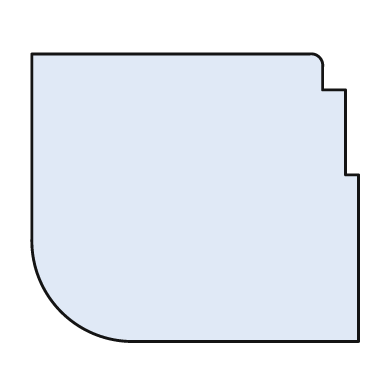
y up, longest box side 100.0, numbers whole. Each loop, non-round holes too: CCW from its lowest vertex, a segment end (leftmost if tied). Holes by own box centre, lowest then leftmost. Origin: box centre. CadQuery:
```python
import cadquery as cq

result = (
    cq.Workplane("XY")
    .moveTo(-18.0, -44.0)
    .lineTo(50.0, -44.0)
    .lineTo(50.0, 7.0)
    .lineTo(46.0, 7.0)
    .lineTo(46.0, 33.0)
    .lineTo(39.0, 33.0)
    .lineTo(39.0, 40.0)
    .threePointArc((38.0, 43.0), (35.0, 44.0))
    .lineTo(-50.0, 44.0)
    .lineTo(-50.0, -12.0)
    .threePointArc((-41.0, -35.0), (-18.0, -44.0))
    .close()
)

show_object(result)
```